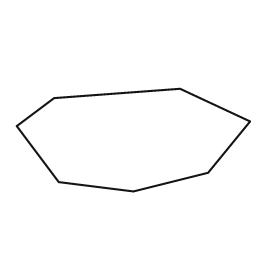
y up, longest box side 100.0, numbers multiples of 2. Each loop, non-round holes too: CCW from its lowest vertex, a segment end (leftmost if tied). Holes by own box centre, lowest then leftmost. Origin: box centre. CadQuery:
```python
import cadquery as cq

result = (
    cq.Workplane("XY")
    .moveTo(0.0, -22.0)
    .lineTo(32.0, -14.0)
    .lineTo(50.0, 8.0)
    .lineTo(20.0, 22.0)
    .lineTo(-34.0, 18.0)
    .lineTo(-50.0, 6.0)
    .lineTo(-32.0, -18.0)
    .close()
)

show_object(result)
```